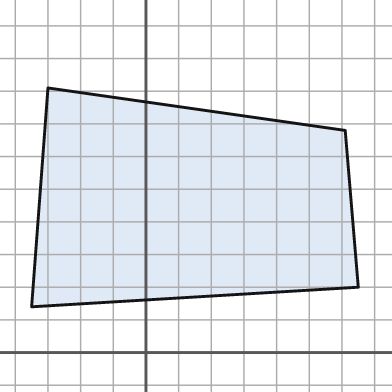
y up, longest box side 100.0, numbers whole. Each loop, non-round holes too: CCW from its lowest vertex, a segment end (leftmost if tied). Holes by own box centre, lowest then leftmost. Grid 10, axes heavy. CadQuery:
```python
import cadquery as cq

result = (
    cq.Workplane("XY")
    .moveTo(-35.0, 14.0)
    .lineTo(65.0, 20.0)
    .lineTo(61.0, 68.0)
    .lineTo(-30.0, 81.0)
    .close()
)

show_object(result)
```